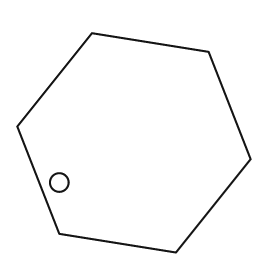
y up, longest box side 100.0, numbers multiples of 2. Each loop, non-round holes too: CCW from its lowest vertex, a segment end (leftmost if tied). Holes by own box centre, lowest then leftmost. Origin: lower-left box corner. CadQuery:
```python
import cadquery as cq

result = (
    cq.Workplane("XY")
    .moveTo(68.0, 0.0)
    .lineTo(100.0, 40.0)
    .lineTo(82.0, 86.0)
    .lineTo(32.0, 94.0)
    .lineTo(0.0, 54.0)
    .lineTo(18.0, 8.0)
    .close()
    .moveTo(18.0, 30.0)
    .circle(4.0)
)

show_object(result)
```